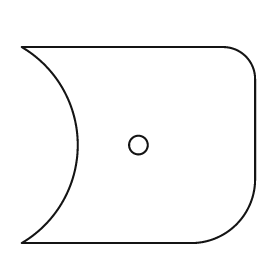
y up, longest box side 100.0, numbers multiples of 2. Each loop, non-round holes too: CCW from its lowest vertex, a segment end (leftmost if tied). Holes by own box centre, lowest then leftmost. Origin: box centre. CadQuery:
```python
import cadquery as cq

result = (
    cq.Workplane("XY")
    .moveTo(-50.0, -42.0)
    .lineTo(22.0, -42.0)
    .threePointArc((42.0, -34.0), (50.0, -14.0))
    .lineTo(50.0, 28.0)
    .threePointArc((46.0, 38.0), (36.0, 42.0))
    .lineTo(-50.0, 42.0)
    .threePointArc((-26.0, 0.0), (-50.0, -42.0))
    .close()
    .moveTo(0.0, 0.0)
    .circle(4.0)
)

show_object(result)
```